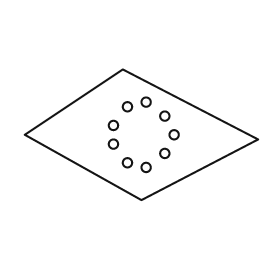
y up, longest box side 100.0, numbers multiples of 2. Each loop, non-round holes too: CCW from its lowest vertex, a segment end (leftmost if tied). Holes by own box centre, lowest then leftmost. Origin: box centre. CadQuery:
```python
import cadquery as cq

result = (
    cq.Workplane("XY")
    .moveTo(0.0, -28.0)
    .lineTo(50.0, -2.0)
    .lineTo(-8.0, 28.0)
    .lineTo(-50.0, 0.0)
    .close()
    .moveTo(2.0, -14.0)
    .circle(2.0)
    .moveTo(-6.0, -12.0)
    .circle(2.0)
    .moveTo(10.0, -8.0)
    .circle(2.0)
    .moveTo(-12.0, -4.0)
    .circle(2.0)
    .moveTo(14.0, 0.0)
    .circle(2.0)
    .moveTo(-12.0, 4.0)
    .circle(2.0)
    .moveTo(10.0, 8.0)
    .circle(2.0)
    .moveTo(-6.0, 12.0)
    .circle(2.0)
    .moveTo(2.0, 14.0)
    .circle(2.0)
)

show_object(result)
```